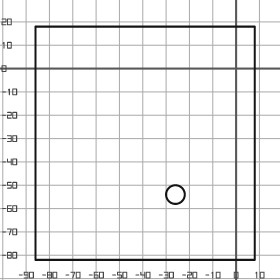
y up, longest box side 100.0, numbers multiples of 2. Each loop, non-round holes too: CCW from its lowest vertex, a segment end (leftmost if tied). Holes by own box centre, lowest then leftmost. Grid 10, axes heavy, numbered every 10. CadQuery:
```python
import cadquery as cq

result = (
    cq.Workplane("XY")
    .moveTo(-86.0, -82.0)
    .lineTo(8.0, -82.0)
    .lineTo(8.0, 18.0)
    .lineTo(-86.0, 18.0)
    .close()
    .moveTo(-26.0, -54.0)
    .circle(4.0)
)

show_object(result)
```